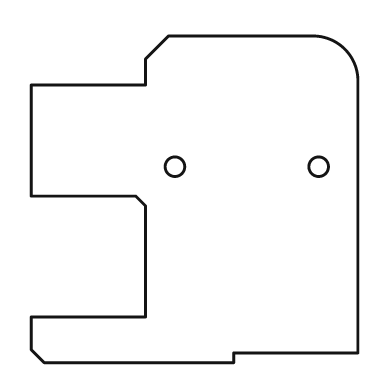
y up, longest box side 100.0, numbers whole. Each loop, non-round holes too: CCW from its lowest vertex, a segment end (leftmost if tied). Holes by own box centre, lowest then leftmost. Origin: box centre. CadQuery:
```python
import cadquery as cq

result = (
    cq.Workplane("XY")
    .moveTo(-46.0, -50.0)
    .lineTo(12.0, -50.0)
    .lineTo(12.0, -47.0)
    .lineTo(50.0, -47.0)
    .lineTo(50.0, 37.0)
    .threePointArc((46.0, 46.0), (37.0, 50.0))
    .lineTo(-8.0, 50.0)
    .lineTo(-15.0, 43.0)
    .lineTo(-15.0, 35.0)
    .lineTo(-50.0, 35.0)
    .lineTo(-50.0, 1.0)
    .lineTo(-18.0, 1.0)
    .lineTo(-15.0, -2.0)
    .lineTo(-15.0, -36.0)
    .lineTo(-50.0, -36.0)
    .lineTo(-50.0, -46.0)
    .close()
    .moveTo(-6.0, 10.0)
    .circle(3.0)
    .moveTo(38.0, 10.0)
    .circle(3.0)
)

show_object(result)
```